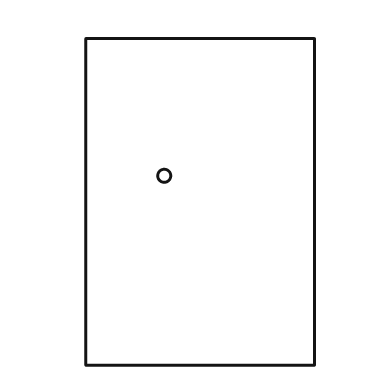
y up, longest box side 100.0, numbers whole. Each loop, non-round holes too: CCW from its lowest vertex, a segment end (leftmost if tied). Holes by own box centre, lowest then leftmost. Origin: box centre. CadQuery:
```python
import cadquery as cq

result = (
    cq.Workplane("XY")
    .moveTo(-35.0, -50.0)
    .lineTo(35.0, -50.0)
    .lineTo(35.0, 50.0)
    .lineTo(-35.0, 50.0)
    .close()
    .moveTo(-11.0, 8.0)
    .circle(2.0)
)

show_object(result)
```